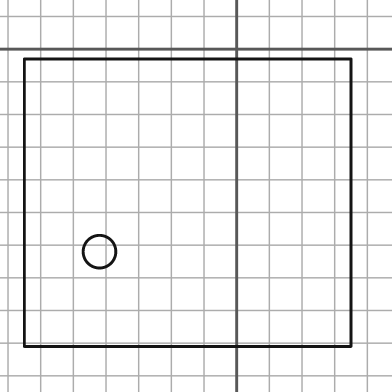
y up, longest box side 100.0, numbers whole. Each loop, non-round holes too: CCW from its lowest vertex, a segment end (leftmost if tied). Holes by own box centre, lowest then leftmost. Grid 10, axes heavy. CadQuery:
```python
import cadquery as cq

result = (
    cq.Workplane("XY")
    .moveTo(-65.0, -91.0)
    .lineTo(35.0, -91.0)
    .lineTo(35.0, -3.0)
    .lineTo(-65.0, -3.0)
    .close()
    .moveTo(-42.0, -62.0)
    .circle(5.0)
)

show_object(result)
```